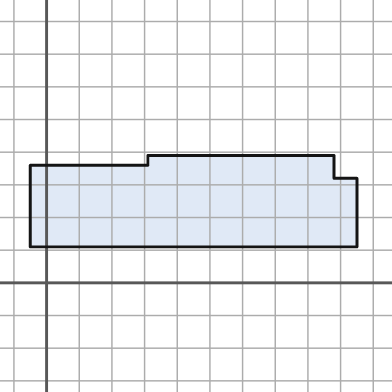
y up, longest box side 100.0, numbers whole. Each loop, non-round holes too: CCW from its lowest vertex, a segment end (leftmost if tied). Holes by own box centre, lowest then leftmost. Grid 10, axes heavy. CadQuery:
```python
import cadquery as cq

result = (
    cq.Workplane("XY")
    .moveTo(-5.0, 11.0)
    .lineTo(95.0, 11.0)
    .lineTo(95.0, 32.0)
    .lineTo(88.0, 32.0)
    .lineTo(88.0, 39.0)
    .lineTo(31.0, 39.0)
    .lineTo(31.0, 36.0)
    .lineTo(-5.0, 36.0)
    .close()
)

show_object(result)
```